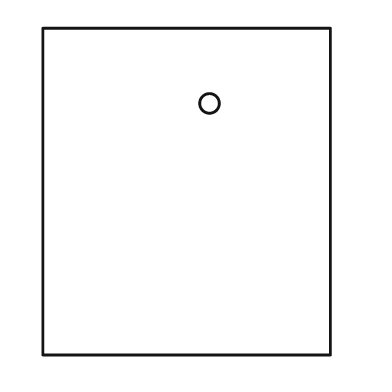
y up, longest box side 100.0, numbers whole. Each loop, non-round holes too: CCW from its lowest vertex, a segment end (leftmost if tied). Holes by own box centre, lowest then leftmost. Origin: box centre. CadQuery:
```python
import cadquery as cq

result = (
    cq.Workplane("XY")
    .moveTo(-44.0, -50.0)
    .lineTo(44.0, -50.0)
    .lineTo(44.0, 50.0)
    .lineTo(-44.0, 50.0)
    .close()
    .moveTo(7.0, 27.0)
    .circle(3.0)
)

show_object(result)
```